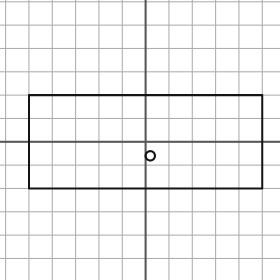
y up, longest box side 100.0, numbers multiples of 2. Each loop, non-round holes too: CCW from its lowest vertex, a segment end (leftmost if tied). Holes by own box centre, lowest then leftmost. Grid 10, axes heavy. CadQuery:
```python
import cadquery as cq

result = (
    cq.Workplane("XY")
    .moveTo(-50.0, -20.0)
    .lineTo(50.0, -20.0)
    .lineTo(50.0, 20.0)
    .lineTo(-50.0, 20.0)
    .close()
    .moveTo(2.0, -6.0)
    .circle(2.0)
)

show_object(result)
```